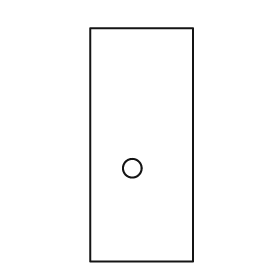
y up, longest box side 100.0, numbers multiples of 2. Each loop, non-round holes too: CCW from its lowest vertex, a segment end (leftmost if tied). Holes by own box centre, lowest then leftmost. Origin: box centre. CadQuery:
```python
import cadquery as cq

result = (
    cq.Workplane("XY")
    .moveTo(-22.0, -50.0)
    .lineTo(22.0, -50.0)
    .lineTo(22.0, 50.0)
    .lineTo(-22.0, 50.0)
    .close()
    .moveTo(-4.0, -10.0)
    .circle(4.0)
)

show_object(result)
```